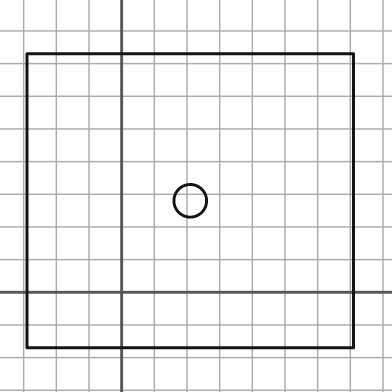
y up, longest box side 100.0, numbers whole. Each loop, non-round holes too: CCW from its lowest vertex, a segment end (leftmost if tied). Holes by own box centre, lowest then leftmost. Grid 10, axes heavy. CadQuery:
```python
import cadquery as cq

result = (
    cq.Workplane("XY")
    .moveTo(-29.0, -17.0)
    .lineTo(71.0, -17.0)
    .lineTo(71.0, 73.0)
    .lineTo(-29.0, 73.0)
    .close()
    .moveTo(21.0, 28.0)
    .circle(5.0)
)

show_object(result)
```